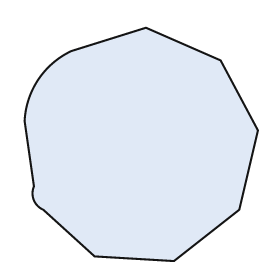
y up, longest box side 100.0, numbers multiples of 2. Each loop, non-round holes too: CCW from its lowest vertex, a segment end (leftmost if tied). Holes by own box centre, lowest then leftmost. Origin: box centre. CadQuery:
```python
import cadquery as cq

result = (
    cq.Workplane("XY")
    .moveTo(14.0, -50.0)
    .lineTo(42.0, -28.0)
    .lineTo(50.0, 6.0)
    .lineTo(34.0, 36.0)
    .lineTo(2.0, 50.0)
    .lineTo(-30.0, 40.0)
    .threePointArc((-44.0, 28.0), (-50.0, 10.0))
    .lineTo(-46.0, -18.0)
    .threePointArc((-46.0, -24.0), (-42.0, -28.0))
    .lineTo(-20.0, -48.0)
    .close()
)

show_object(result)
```